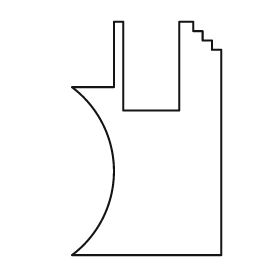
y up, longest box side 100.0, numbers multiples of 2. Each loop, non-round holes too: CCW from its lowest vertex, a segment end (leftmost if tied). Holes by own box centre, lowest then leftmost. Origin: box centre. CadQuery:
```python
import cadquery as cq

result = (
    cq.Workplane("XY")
    .moveTo(-32.0, -50.0)
    .lineTo(32.0, -50.0)
    .lineTo(32.0, 38.0)
    .lineTo(28.0, 38.0)
    .lineTo(28.0, 42.0)
    .lineTo(24.0, 42.0)
    .lineTo(24.0, 46.0)
    .lineTo(20.0, 46.0)
    .lineTo(20.0, 50.0)
    .lineTo(14.0, 50.0)
    .lineTo(14.0, 12.0)
    .lineTo(-10.0, 12.0)
    .lineTo(-10.0, 50.0)
    .lineTo(-14.0, 50.0)
    .lineTo(-14.0, 22.0)
    .lineTo(-32.0, 22.0)
    .threePointArc((-14.0, -14.0), (-32.0, -50.0))
    .close()
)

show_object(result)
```